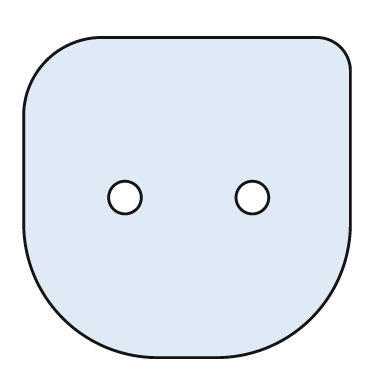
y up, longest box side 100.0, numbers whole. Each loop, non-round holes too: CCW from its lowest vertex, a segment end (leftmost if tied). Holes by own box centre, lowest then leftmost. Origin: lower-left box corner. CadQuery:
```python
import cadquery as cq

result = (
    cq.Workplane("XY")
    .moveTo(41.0, 0.0)
    .lineTo(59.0, 0.0)
    .threePointArc((88.0, 12.0), (100.0, 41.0))
    .lineTo(100.0, 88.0)
    .threePointArc((97.0, 95.0), (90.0, 98.0))
    .lineTo(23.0, 98.0)
    .threePointArc((7.0, 91.0), (0.0, 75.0))
    .lineTo(0.0, 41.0)
    .threePointArc((12.0, 12.0), (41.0, 0.0))
    .close()
    .moveTo(31.0, 49.0)
    .circle(5.0)
    .moveTo(70.0, 49.0)
    .circle(5.0)
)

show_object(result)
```